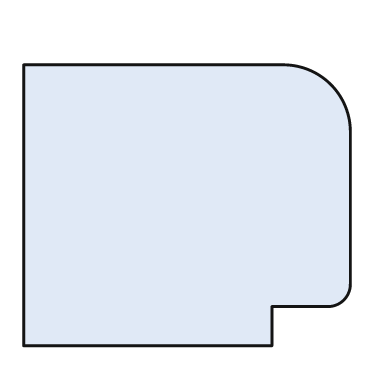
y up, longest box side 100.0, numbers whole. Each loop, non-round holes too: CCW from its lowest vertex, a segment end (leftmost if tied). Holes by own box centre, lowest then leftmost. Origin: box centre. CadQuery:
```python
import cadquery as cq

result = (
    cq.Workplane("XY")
    .moveTo(-50.0, -43.0)
    .lineTo(26.0, -43.0)
    .lineTo(26.0, -31.0)
    .lineTo(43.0, -31.0)
    .threePointArc((48.0, -29.0), (50.0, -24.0))
    .lineTo(50.0, 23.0)
    .threePointArc((44.0, 37.0), (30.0, 43.0))
    .lineTo(-50.0, 43.0)
    .close()
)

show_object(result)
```